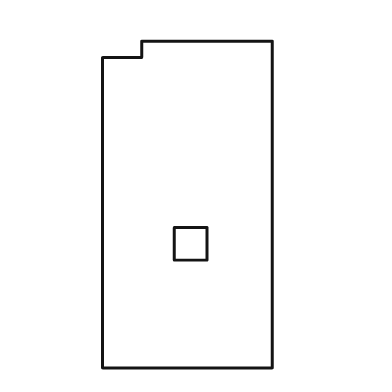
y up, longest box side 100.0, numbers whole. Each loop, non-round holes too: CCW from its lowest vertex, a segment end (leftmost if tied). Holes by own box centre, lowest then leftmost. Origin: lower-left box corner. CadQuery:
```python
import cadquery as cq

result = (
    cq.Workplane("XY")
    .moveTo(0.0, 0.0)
    .lineTo(52.0, 0.0)
    .lineTo(52.0, 100.0)
    .lineTo(12.0, 100.0)
    .lineTo(12.0, 95.0)
    .lineTo(0.0, 95.0)
    .close()
    .moveTo(22.0, 33.0)
    .lineTo(32.0, 33.0)
    .lineTo(32.0, 43.0)
    .lineTo(22.0, 43.0)
    .close()
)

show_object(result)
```